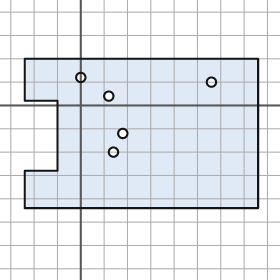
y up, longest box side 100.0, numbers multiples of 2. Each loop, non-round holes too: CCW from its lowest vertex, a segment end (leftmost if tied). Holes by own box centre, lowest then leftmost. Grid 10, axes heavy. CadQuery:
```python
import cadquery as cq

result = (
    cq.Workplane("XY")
    .moveTo(-24.0, -44.0)
    .lineTo(76.0, -44.0)
    .lineTo(76.0, 20.0)
    .lineTo(-24.0, 20.0)
    .lineTo(-24.0, 2.0)
    .lineTo(-10.0, 2.0)
    .lineTo(-10.0, -28.0)
    .lineTo(-24.0, -28.0)
    .close()
    .moveTo(14.0, -20.0)
    .circle(2.0)
    .moveTo(18.0, -12.0)
    .circle(2.0)
    .moveTo(12.0, 4.0)
    .circle(2.0)
    .moveTo(56.0, 10.0)
    .circle(2.0)
    .moveTo(0.0, 12.0)
    .circle(2.0)
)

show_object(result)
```